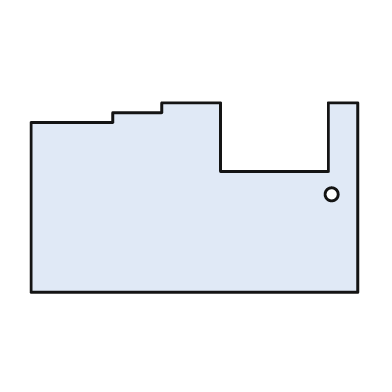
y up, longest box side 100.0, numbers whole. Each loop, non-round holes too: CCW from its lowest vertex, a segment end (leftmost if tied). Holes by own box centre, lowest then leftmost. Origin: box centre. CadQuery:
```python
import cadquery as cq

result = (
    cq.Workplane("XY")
    .moveTo(-50.0, -29.0)
    .lineTo(50.0, -29.0)
    .lineTo(50.0, 29.0)
    .lineTo(41.0, 29.0)
    .lineTo(41.0, 8.0)
    .lineTo(8.0, 8.0)
    .lineTo(8.0, 29.0)
    .lineTo(-10.0, 29.0)
    .lineTo(-10.0, 26.0)
    .lineTo(-25.0, 26.0)
    .lineTo(-25.0, 23.0)
    .lineTo(-50.0, 23.0)
    .close()
    .moveTo(42.0, 1.0)
    .circle(2.0)
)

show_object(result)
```